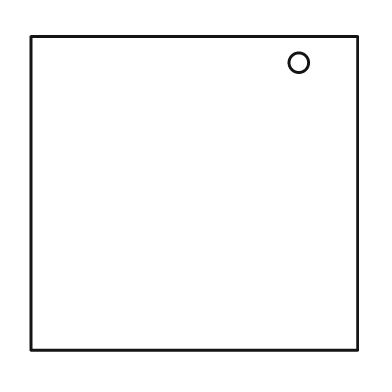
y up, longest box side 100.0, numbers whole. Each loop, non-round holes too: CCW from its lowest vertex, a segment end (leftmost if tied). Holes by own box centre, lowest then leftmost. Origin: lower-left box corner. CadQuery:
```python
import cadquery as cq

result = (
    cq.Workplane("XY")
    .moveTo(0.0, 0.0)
    .lineTo(100.0, 0.0)
    .lineTo(100.0, 96.0)
    .lineTo(0.0, 96.0)
    .close()
    .moveTo(82.0, 88.0)
    .circle(3.0)
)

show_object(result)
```